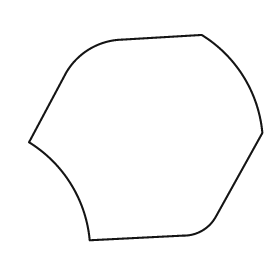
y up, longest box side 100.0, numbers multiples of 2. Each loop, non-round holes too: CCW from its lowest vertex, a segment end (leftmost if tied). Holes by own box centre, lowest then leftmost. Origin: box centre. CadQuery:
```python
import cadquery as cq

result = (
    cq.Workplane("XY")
    .moveTo(-24.0, -44.0)
    .lineTo(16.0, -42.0)
    .threePointArc((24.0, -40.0), (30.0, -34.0))
    .lineTo(50.0, 2.0)
    .threePointArc((42.0, 26.0), (24.0, 44.0))
    .lineTo(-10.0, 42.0)
    .threePointArc((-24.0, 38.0), (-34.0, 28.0))
    .lineTo(-50.0, -2.0)
    .threePointArc((-32.0, -20.0), (-24.0, -44.0))
    .close()
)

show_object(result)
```